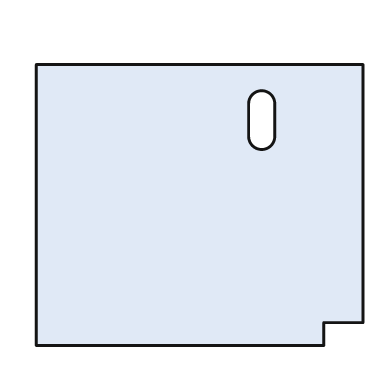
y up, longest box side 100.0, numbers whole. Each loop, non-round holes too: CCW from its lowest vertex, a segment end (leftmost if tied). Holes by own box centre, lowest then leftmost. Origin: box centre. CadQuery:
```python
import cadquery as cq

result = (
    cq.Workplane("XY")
    .moveTo(-50.0, -43.0)
    .lineTo(38.0, -43.0)
    .lineTo(38.0, -36.0)
    .lineTo(50.0, -36.0)
    .lineTo(50.0, 43.0)
    .lineTo(-50.0, 43.0)
    .close()
    .moveTo(15.0, 21.0)
    .threePointArc((19.0, 17.0), (23.0, 21.0))
    .lineTo(23.0, 31.0)
    .threePointArc((19.0, 35.0), (15.0, 31.0))
    .close()
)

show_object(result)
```